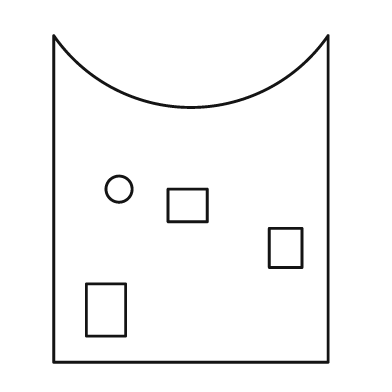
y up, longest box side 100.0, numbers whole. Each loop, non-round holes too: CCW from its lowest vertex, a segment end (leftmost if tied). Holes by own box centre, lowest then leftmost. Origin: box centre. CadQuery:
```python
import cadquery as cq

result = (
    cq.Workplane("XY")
    .moveTo(-42.0, -50.0)
    .lineTo(42.0, -50.0)
    .lineTo(42.0, 50.0)
    .threePointArc((0.0, 28.0), (-42.0, 50.0))
    .close()
    .moveTo(-32.0, -42.0)
    .lineTo(-20.0, -42.0)
    .lineTo(-20.0, -26.0)
    .lineTo(-32.0, -26.0)
    .close()
    .moveTo(24.0, -21.0)
    .lineTo(34.0, -21.0)
    .lineTo(34.0, -9.0)
    .lineTo(24.0, -9.0)
    .close()
    .moveTo(-7.0, -7.0)
    .lineTo(5.0, -7.0)
    .lineTo(5.0, 3.0)
    .lineTo(-7.0, 3.0)
    .close()
    .moveTo(-22.0, 3.0)
    .circle(4.0)
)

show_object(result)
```